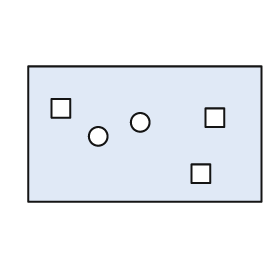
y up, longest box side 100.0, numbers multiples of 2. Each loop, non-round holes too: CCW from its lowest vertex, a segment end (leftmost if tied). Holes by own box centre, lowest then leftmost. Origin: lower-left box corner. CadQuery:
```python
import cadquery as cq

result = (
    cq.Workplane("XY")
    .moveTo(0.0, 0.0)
    .lineTo(100.0, 0.0)
    .lineTo(100.0, 58.0)
    .lineTo(0.0, 58.0)
    .close()
    .moveTo(70.0, 8.0)
    .lineTo(78.0, 8.0)
    .lineTo(78.0, 16.0)
    .lineTo(70.0, 16.0)
    .close()
    .moveTo(30.0, 28.0)
    .circle(4.0)
    .moveTo(48.0, 34.0)
    .circle(4.0)
    .moveTo(76.0, 32.0)
    .lineTo(84.0, 32.0)
    .lineTo(84.0, 40.0)
    .lineTo(76.0, 40.0)
    .close()
    .moveTo(10.0, 36.0)
    .lineTo(18.0, 36.0)
    .lineTo(18.0, 44.0)
    .lineTo(10.0, 44.0)
    .close()
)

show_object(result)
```